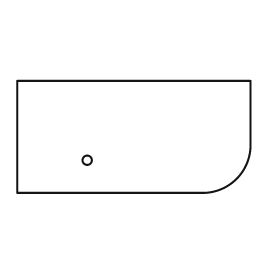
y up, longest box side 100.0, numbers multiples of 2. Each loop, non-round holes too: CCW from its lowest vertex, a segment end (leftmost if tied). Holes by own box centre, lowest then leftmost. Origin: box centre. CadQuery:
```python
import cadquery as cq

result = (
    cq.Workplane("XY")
    .moveTo(-50.0, -24.0)
    .lineTo(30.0, -24.0)
    .threePointArc((44.0, -18.0), (50.0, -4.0))
    .lineTo(50.0, 24.0)
    .lineTo(-50.0, 24.0)
    .close()
    .moveTo(-20.0, -10.0)
    .circle(2.0)
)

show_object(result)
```